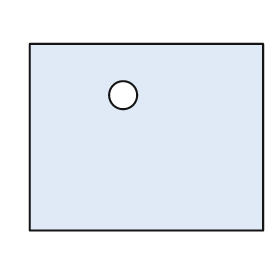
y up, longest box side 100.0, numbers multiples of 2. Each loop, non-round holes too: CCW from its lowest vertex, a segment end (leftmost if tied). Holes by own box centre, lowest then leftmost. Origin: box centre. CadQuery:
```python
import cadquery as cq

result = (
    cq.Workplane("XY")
    .moveTo(-50.0, -40.0)
    .lineTo(50.0, -40.0)
    .lineTo(50.0, 40.0)
    .lineTo(-50.0, 40.0)
    .close()
    .moveTo(-10.0, 18.0)
    .circle(6.0)
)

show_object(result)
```